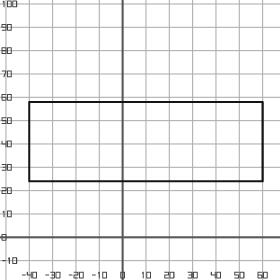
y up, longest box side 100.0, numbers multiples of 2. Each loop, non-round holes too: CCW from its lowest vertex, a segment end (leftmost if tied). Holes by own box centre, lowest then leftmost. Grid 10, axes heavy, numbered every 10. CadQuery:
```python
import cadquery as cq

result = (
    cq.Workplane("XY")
    .moveTo(-40.0, 24.0)
    .lineTo(60.0, 24.0)
    .lineTo(60.0, 58.0)
    .lineTo(-40.0, 58.0)
    .close()
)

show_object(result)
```